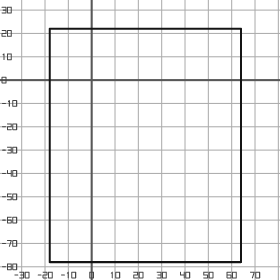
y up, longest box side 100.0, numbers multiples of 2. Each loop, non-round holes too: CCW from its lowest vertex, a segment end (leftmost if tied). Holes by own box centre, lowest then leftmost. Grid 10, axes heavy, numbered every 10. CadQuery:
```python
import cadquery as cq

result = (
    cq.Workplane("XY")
    .moveTo(-18.0, -78.0)
    .lineTo(64.0, -78.0)
    .lineTo(64.0, 22.0)
    .lineTo(-18.0, 22.0)
    .close()
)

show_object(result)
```